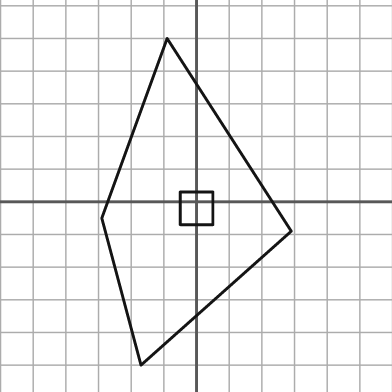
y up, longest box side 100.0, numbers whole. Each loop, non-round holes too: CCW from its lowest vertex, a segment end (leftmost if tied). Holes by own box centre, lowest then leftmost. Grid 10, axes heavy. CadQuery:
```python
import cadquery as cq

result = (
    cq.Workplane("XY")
    .moveTo(-17.0, -50.0)
    .lineTo(29.0, -9.0)
    .lineTo(-9.0, 50.0)
    .lineTo(-29.0, -5.0)
    .close()
    .moveTo(-5.0, -7.0)
    .lineTo(5.0, -7.0)
    .lineTo(5.0, 3.0)
    .lineTo(-5.0, 3.0)
    .close()
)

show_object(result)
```